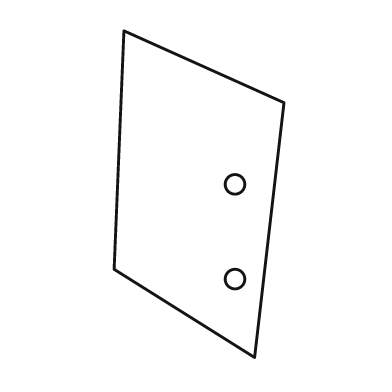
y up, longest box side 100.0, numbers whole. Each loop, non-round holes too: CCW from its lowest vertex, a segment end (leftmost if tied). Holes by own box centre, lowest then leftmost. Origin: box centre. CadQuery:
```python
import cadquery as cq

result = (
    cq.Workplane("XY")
    .moveTo(17.0, -50.0)
    .lineTo(26.0, 28.0)
    .lineTo(-23.0, 50.0)
    .lineTo(-26.0, -23.0)
    .close()
    .moveTo(11.0, -26.0)
    .circle(3.0)
    .moveTo(11.0, 3.0)
    .circle(3.0)
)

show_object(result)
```